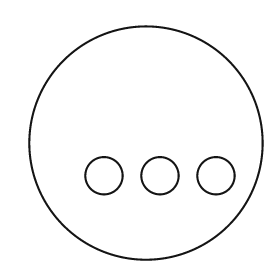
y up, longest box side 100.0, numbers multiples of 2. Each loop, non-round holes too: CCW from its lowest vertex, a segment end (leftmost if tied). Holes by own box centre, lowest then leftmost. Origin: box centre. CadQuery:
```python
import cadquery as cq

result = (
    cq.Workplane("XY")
    .moveTo(0.0, 0.0)
    .circle(50.0)
    .moveTo(-18.0, -14.0)
    .circle(8.0)
    .moveTo(6.0, -14.0)
    .circle(8.0)
    .moveTo(30.0, -14.0)
    .circle(8.0)
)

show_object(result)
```